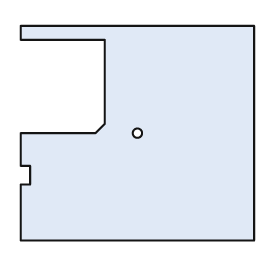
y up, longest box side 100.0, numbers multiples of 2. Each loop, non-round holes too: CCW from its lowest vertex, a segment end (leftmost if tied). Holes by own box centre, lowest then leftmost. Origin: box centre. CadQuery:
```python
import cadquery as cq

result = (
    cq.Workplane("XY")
    .moveTo(-50.0, -46.0)
    .lineTo(50.0, -46.0)
    .lineTo(50.0, 46.0)
    .lineTo(-50.0, 46.0)
    .lineTo(-50.0, 40.0)
    .lineTo(-14.0, 40.0)
    .lineTo(-14.0, 4.0)
    .lineTo(-18.0, 0.0)
    .lineTo(-50.0, 0.0)
    .lineTo(-50.0, -14.0)
    .lineTo(-46.0, -14.0)
    .lineTo(-46.0, -22.0)
    .lineTo(-50.0, -22.0)
    .close()
    .moveTo(0.0, 0.0)
    .circle(2.0)
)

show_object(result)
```